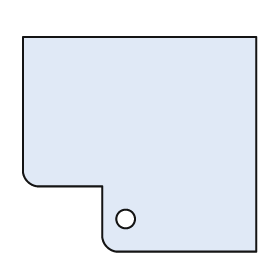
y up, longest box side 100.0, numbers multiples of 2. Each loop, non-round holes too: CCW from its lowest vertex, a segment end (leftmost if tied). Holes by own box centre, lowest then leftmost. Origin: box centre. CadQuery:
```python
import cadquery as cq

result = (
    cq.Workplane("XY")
    .moveTo(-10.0, -46.0)
    .lineTo(50.0, -46.0)
    .lineTo(50.0, 46.0)
    .lineTo(-50.0, 46.0)
    .lineTo(-50.0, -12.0)
    .threePointArc((-48.0, -16.0), (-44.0, -18.0))
    .lineTo(-16.0, -18.0)
    .lineTo(-16.0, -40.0)
    .threePointArc((-14.0, -44.0), (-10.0, -46.0))
    .close()
    .moveTo(-6.0, -32.0)
    .circle(4.0)
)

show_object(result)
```